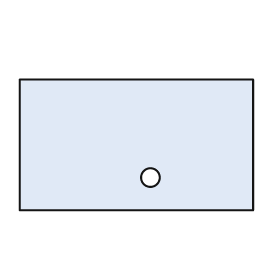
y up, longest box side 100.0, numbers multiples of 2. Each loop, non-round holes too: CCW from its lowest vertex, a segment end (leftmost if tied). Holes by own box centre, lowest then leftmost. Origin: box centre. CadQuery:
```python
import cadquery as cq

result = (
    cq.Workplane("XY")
    .moveTo(-50.0, -28.0)
    .lineTo(50.0, -28.0)
    .lineTo(50.0, 28.0)
    .lineTo(-50.0, 28.0)
    .close()
    .moveTo(6.0, -14.0)
    .circle(4.0)
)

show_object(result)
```